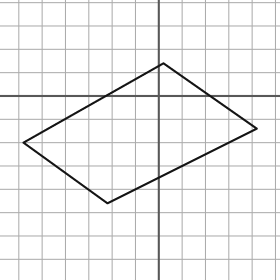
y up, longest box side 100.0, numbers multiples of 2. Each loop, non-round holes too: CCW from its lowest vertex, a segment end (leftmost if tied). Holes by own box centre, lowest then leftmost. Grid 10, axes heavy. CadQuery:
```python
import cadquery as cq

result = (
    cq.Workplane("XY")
    .moveTo(-22.0, -46.0)
    .lineTo(42.0, -14.0)
    .lineTo(2.0, 14.0)
    .lineTo(-58.0, -20.0)
    .close()
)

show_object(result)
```